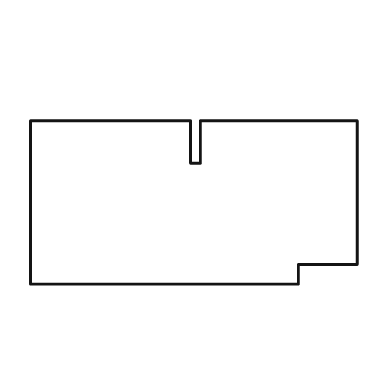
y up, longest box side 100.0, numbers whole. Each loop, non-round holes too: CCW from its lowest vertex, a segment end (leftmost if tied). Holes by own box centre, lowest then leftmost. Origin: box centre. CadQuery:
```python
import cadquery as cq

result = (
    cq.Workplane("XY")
    .moveTo(-50.0, -25.0)
    .lineTo(32.0, -25.0)
    .lineTo(32.0, -19.0)
    .lineTo(50.0, -19.0)
    .lineTo(50.0, 25.0)
    .lineTo(2.0, 25.0)
    .lineTo(2.0, 12.0)
    .lineTo(-1.0, 12.0)
    .lineTo(-1.0, 25.0)
    .lineTo(-50.0, 25.0)
    .close()
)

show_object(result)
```